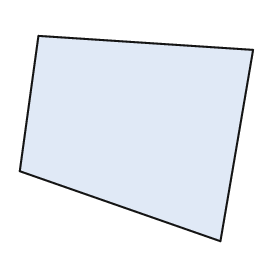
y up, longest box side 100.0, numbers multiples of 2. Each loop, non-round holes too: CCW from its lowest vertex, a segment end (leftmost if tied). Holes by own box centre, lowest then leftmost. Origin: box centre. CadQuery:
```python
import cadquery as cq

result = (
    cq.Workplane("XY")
    .moveTo(36.0, -44.0)
    .lineTo(50.0, 38.0)
    .lineTo(-42.0, 44.0)
    .lineTo(-50.0, -14.0)
    .close()
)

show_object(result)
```